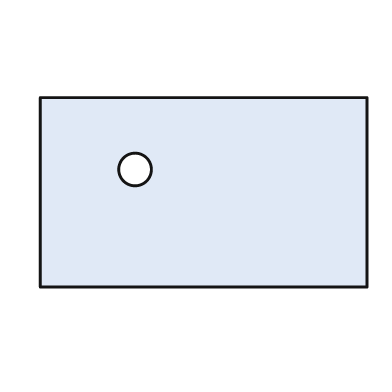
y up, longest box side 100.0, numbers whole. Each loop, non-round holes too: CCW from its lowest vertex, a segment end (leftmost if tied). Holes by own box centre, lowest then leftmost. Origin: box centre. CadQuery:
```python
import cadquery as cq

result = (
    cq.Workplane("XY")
    .moveTo(-50.0, -29.0)
    .lineTo(50.0, -29.0)
    .lineTo(50.0, 29.0)
    .lineTo(-50.0, 29.0)
    .close()
    .moveTo(-21.0, 7.0)
    .circle(5.0)
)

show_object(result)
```